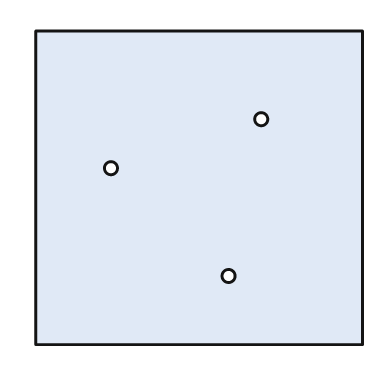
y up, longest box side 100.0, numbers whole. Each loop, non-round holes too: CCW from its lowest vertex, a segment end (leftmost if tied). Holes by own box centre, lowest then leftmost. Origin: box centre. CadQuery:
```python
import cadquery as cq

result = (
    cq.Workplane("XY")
    .moveTo(-50.0, -48.0)
    .lineTo(50.0, -48.0)
    .lineTo(50.0, 48.0)
    .lineTo(-50.0, 48.0)
    .close()
    .moveTo(9.0, -27.0)
    .circle(2.0)
    .moveTo(-27.0, 6.0)
    .circle(2.0)
    .moveTo(19.0, 21.0)
    .circle(2.0)
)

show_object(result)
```